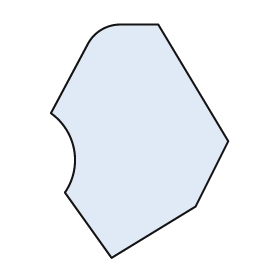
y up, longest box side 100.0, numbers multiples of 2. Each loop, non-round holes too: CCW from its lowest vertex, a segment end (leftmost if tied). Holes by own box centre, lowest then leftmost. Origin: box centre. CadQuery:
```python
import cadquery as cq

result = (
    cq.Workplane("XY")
    .moveTo(-12.0, -50.0)
    .lineTo(24.0, -28.0)
    .lineTo(38.0, 0.0)
    .lineTo(8.0, 50.0)
    .lineTo(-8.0, 50.0)
    .threePointArc((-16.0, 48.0), (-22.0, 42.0))
    .lineTo(-38.0, 12.0)
    .threePointArc((-28.0, -4.0), (-32.0, -22.0))
    .close()
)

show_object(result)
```